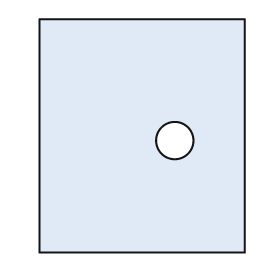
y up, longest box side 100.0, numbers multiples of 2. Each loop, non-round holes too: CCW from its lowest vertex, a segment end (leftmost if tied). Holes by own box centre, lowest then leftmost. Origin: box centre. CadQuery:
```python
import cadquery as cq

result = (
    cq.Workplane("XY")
    .moveTo(-44.0, -50.0)
    .lineTo(44.0, -50.0)
    .lineTo(44.0, 50.0)
    .lineTo(-44.0, 50.0)
    .close()
    .moveTo(14.0, -2.0)
    .circle(8.0)
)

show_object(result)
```